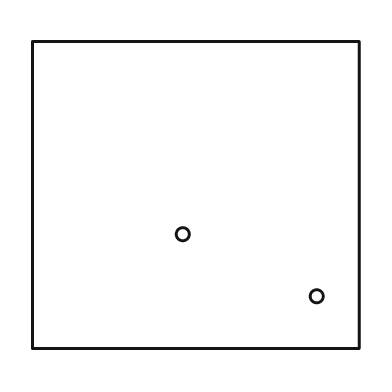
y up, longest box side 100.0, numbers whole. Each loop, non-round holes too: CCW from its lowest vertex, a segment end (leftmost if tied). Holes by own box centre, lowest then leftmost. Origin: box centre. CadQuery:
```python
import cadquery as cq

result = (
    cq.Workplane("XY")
    .moveTo(-50.0, -47.0)
    .lineTo(50.0, -47.0)
    .lineTo(50.0, 47.0)
    .lineTo(-50.0, 47.0)
    .close()
    .moveTo(37.0, -31.0)
    .circle(2.0)
    .moveTo(-4.0, -12.0)
    .circle(2.0)
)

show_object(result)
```